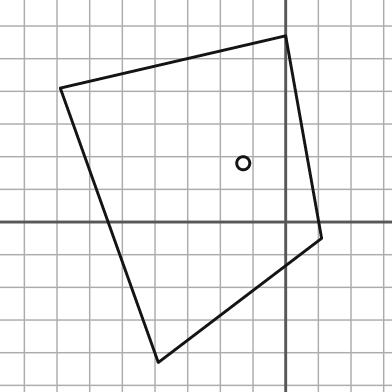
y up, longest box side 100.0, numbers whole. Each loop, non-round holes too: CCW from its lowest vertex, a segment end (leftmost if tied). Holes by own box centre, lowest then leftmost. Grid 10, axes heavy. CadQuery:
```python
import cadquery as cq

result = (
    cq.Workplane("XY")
    .moveTo(-39.0, -43.0)
    .lineTo(11.0, -5.0)
    .lineTo(0.0, 57.0)
    .lineTo(-69.0, 41.0)
    .close()
    .moveTo(-13.0, 18.0)
    .circle(2.0)
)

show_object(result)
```